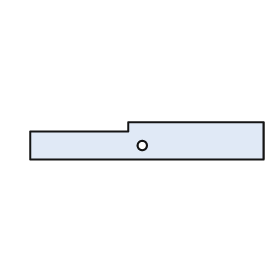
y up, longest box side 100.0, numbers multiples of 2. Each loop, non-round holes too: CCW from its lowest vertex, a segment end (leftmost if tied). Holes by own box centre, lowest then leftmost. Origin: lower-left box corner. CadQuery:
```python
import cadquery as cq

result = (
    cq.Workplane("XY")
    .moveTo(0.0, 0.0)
    .lineTo(100.0, 0.0)
    .lineTo(100.0, 16.0)
    .lineTo(42.0, 16.0)
    .lineTo(42.0, 12.0)
    .lineTo(0.0, 12.0)
    .close()
    .moveTo(48.0, 6.0)
    .circle(2.0)
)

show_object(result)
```